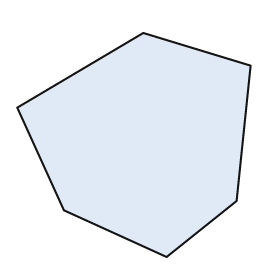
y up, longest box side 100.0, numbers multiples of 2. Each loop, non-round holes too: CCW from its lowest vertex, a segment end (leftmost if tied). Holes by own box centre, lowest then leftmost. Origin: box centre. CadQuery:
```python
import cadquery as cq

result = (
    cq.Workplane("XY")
    .moveTo(14.0, -48.0)
    .lineTo(44.0, -24.0)
    .lineTo(50.0, 34.0)
    .lineTo(4.0, 48.0)
    .lineTo(-50.0, 16.0)
    .lineTo(-30.0, -28.0)
    .close()
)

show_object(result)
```